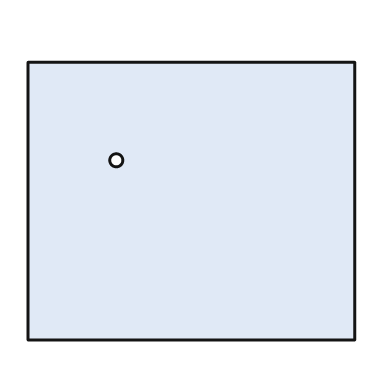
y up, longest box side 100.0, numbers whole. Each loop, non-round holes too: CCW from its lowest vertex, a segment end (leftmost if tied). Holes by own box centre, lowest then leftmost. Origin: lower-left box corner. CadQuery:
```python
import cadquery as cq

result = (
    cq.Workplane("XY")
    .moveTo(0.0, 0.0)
    .lineTo(100.0, 0.0)
    .lineTo(100.0, 85.0)
    .lineTo(0.0, 85.0)
    .close()
    .moveTo(27.0, 55.0)
    .circle(2.0)
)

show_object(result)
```